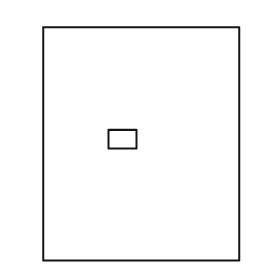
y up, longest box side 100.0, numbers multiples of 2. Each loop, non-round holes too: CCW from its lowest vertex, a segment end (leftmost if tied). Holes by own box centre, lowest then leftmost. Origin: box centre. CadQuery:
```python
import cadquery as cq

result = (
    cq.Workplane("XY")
    .moveTo(-42.0, -50.0)
    .lineTo(42.0, -50.0)
    .lineTo(42.0, 50.0)
    .lineTo(-42.0, 50.0)
    .close()
    .moveTo(-14.0, -2.0)
    .lineTo(-2.0, -2.0)
    .lineTo(-2.0, 6.0)
    .lineTo(-14.0, 6.0)
    .close()
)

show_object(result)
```